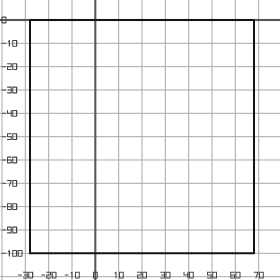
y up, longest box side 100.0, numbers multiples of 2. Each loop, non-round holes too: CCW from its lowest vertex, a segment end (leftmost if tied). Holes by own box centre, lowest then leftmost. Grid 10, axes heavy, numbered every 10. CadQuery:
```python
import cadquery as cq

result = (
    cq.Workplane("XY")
    .moveTo(-28.0, -100.0)
    .lineTo(68.0, -100.0)
    .lineTo(68.0, 0.0)
    .lineTo(-28.0, 0.0)
    .close()
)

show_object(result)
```